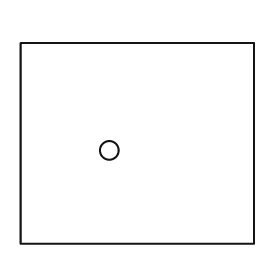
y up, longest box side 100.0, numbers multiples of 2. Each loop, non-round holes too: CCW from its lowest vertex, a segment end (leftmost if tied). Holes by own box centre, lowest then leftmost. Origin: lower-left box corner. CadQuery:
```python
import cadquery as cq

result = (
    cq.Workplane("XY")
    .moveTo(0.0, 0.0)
    .lineTo(100.0, 0.0)
    .lineTo(100.0, 86.0)
    .lineTo(0.0, 86.0)
    .close()
    .moveTo(38.0, 40.0)
    .circle(4.0)
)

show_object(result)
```